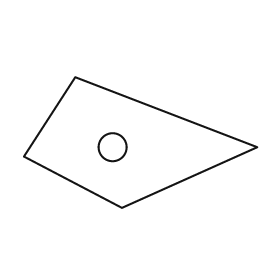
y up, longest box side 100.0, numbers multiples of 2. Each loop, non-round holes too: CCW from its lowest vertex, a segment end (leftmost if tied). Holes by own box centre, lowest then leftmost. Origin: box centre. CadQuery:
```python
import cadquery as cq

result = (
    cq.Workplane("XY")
    .moveTo(-8.0, -28.0)
    .lineTo(50.0, -2.0)
    .lineTo(-28.0, 28.0)
    .lineTo(-50.0, -6.0)
    .close()
    .moveTo(-12.0, -2.0)
    .circle(6.0)
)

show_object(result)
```